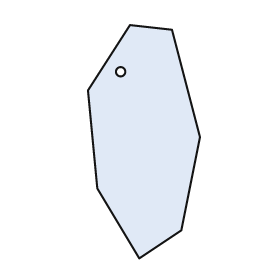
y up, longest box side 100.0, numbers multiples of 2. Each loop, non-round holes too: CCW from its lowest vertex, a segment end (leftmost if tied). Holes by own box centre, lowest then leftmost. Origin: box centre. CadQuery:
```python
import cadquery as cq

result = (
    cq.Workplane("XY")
    .moveTo(-2.0, -50.0)
    .lineTo(16.0, -38.0)
    .lineTo(24.0, 2.0)
    .lineTo(12.0, 48.0)
    .lineTo(-6.0, 50.0)
    .lineTo(-24.0, 22.0)
    .lineTo(-20.0, -20.0)
    .close()
    .moveTo(-10.0, 30.0)
    .circle(2.0)
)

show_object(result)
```